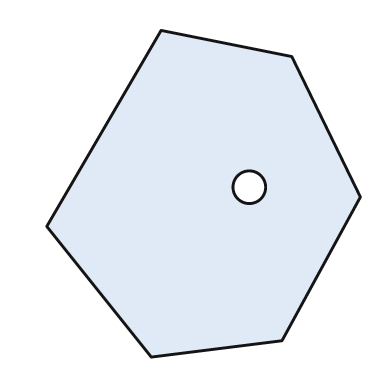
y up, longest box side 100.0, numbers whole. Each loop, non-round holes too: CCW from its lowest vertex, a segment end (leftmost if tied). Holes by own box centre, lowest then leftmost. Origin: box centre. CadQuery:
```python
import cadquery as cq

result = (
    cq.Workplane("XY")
    .moveTo(-16.0, -50.0)
    .lineTo(24.0, -45.0)
    .lineTo(48.0, -1.0)
    .lineTo(27.0, 42.0)
    .lineTo(-13.0, 50.0)
    .lineTo(-48.0, -10.0)
    .close()
    .moveTo(14.0, 2.0)
    .circle(5.0)
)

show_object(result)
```